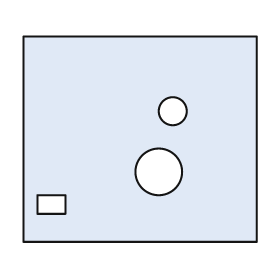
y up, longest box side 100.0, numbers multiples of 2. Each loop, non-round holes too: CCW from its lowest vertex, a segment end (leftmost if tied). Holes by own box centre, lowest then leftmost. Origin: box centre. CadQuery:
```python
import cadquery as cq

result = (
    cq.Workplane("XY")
    .moveTo(-50.0, -44.0)
    .lineTo(50.0, -44.0)
    .lineTo(50.0, 44.0)
    .lineTo(-50.0, 44.0)
    .close()
    .moveTo(-44.0, -32.0)
    .lineTo(-32.0, -32.0)
    .lineTo(-32.0, -24.0)
    .lineTo(-44.0, -24.0)
    .close()
    .moveTo(8.0, -14.0)
    .circle(10.0)
    .moveTo(14.0, 12.0)
    .circle(6.0)
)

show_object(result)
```